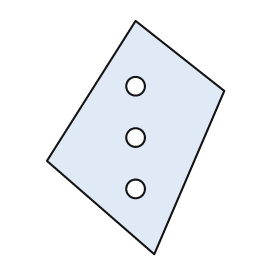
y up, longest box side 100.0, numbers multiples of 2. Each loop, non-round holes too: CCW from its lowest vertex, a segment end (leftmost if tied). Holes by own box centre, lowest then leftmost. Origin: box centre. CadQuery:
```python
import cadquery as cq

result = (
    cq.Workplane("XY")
    .moveTo(8.0, -50.0)
    .lineTo(38.0, 20.0)
    .lineTo(0.0, 50.0)
    .lineTo(-38.0, -10.0)
    .close()
    .moveTo(0.0, -22.0)
    .circle(4.0)
    .moveTo(0.0, 0.0)
    .circle(4.0)
    .moveTo(0.0, 22.0)
    .circle(4.0)
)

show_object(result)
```